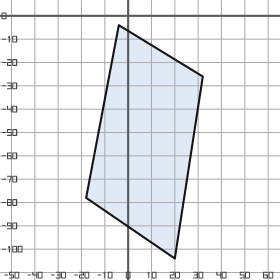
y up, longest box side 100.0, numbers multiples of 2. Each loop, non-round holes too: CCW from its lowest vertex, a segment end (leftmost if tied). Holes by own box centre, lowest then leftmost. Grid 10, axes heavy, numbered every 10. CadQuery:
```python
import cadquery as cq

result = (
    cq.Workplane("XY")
    .moveTo(20.0, -104.0)
    .lineTo(32.0, -26.0)
    .lineTo(-4.0, -4.0)
    .lineTo(-18.0, -78.0)
    .close()
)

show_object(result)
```